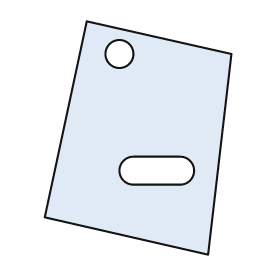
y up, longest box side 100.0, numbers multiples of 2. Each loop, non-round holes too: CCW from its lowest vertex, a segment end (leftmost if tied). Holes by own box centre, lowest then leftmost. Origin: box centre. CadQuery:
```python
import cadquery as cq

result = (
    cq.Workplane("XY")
    .moveTo(30.0, -50.0)
    .lineTo(40.0, 36.0)
    .lineTo(-22.0, 50.0)
    .lineTo(-40.0, -34.0)
    .close()
    .moveTo(-2.0, -20.0)
    .lineTo(18.0, -20.0)
    .threePointArc((24.0, -14.0), (18.0, -8.0))
    .lineTo(-2.0, -8.0)
    .threePointArc((-8.0, -14.0), (-2.0, -20.0))
    .close()
    .moveTo(-8.0, 36.0)
    .circle(6.0)
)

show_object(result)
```